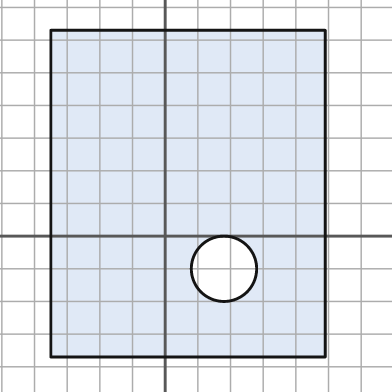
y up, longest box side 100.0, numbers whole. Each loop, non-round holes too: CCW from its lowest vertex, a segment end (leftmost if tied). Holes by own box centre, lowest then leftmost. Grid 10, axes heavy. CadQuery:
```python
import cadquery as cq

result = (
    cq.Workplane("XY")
    .moveTo(-35.0, -37.0)
    .lineTo(49.0, -37.0)
    .lineTo(49.0, 63.0)
    .lineTo(-35.0, 63.0)
    .close()
    .moveTo(18.0, -10.0)
    .circle(10.0)
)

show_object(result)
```